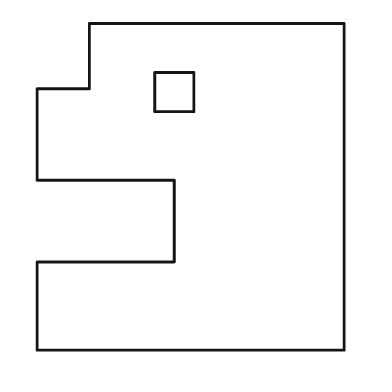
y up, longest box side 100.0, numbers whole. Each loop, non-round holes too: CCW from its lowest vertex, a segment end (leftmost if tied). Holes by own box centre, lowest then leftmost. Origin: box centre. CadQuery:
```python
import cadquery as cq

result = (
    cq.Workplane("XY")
    .moveTo(-47.0, -50.0)
    .lineTo(47.0, -50.0)
    .lineTo(47.0, 50.0)
    .lineTo(-31.0, 50.0)
    .lineTo(-31.0, 30.0)
    .lineTo(-47.0, 30.0)
    .lineTo(-47.0, 2.0)
    .lineTo(-5.0, 2.0)
    .lineTo(-5.0, -23.0)
    .lineTo(-47.0, -23.0)
    .close()
    .moveTo(-11.0, 23.0)
    .lineTo(1.0, 23.0)
    .lineTo(1.0, 35.0)
    .lineTo(-11.0, 35.0)
    .close()
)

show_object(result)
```